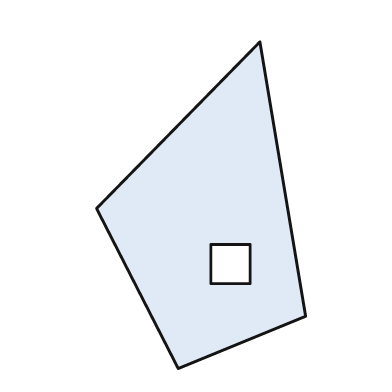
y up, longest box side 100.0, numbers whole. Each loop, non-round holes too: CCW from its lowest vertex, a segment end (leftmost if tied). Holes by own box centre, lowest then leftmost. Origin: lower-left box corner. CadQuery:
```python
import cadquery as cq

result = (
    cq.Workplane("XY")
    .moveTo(25.0, 0.0)
    .lineTo(64.0, 16.0)
    .lineTo(50.0, 100.0)
    .lineTo(0.0, 49.0)
    .close()
    .moveTo(35.0, 26.0)
    .lineTo(47.0, 26.0)
    .lineTo(47.0, 38.0)
    .lineTo(35.0, 38.0)
    .close()
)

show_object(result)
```